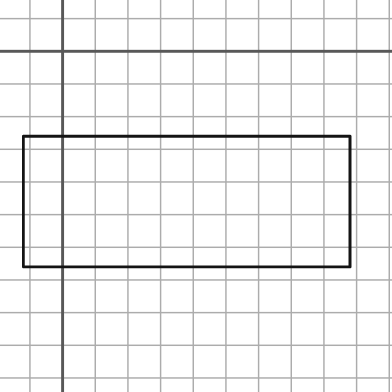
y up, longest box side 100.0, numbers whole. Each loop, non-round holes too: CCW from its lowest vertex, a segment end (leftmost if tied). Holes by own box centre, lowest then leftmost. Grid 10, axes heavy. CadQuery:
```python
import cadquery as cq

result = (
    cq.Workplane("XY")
    .moveTo(-12.0, -66.0)
    .lineTo(88.0, -66.0)
    .lineTo(88.0, -26.0)
    .lineTo(-12.0, -26.0)
    .close()
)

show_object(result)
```